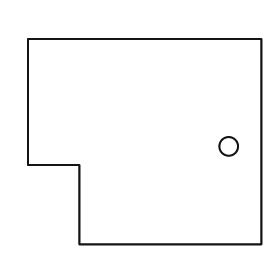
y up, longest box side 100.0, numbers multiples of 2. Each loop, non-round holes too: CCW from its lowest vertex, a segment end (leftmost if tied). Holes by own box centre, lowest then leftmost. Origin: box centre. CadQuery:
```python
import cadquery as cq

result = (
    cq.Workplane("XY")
    .moveTo(-28.0, -44.0)
    .lineTo(50.0, -44.0)
    .lineTo(50.0, 44.0)
    .lineTo(-50.0, 44.0)
    .lineTo(-50.0, -10.0)
    .lineTo(-28.0, -10.0)
    .close()
    .moveTo(36.0, -2.0)
    .circle(4.0)
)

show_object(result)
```